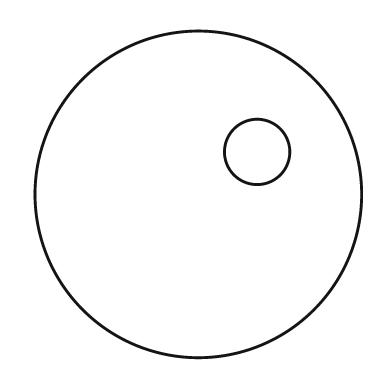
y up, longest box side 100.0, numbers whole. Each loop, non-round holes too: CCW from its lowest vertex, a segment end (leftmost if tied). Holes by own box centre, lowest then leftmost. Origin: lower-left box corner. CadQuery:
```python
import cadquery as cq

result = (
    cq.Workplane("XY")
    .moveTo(50.0, 50.0)
    .circle(50.0)
    .moveTo(68.0, 63.0)
    .circle(10.0)
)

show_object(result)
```